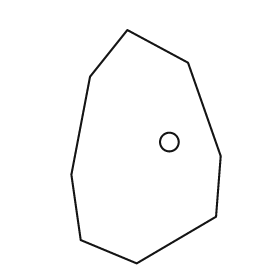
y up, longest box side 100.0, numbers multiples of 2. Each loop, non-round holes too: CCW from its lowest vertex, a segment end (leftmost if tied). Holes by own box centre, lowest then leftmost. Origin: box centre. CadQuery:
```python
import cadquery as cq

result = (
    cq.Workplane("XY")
    .moveTo(-4.0, -50.0)
    .lineTo(30.0, -30.0)
    .lineTo(32.0, -4.0)
    .lineTo(18.0, 36.0)
    .lineTo(-8.0, 50.0)
    .lineTo(-24.0, 30.0)
    .lineTo(-32.0, -12.0)
    .lineTo(-28.0, -40.0)
    .close()
    .moveTo(10.0, 2.0)
    .circle(4.0)
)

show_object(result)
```